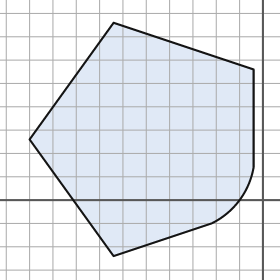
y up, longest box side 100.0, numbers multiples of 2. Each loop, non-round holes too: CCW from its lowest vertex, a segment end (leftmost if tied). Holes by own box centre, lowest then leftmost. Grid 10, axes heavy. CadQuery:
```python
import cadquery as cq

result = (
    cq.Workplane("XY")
    .moveTo(-64.0, -24.0)
    .lineTo(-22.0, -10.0)
    .threePointArc((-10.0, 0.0), (-4.0, 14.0))
    .lineTo(-4.0, 56.0)
    .lineTo(-64.0, 76.0)
    .lineTo(-100.0, 26.0)
    .close()
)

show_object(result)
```